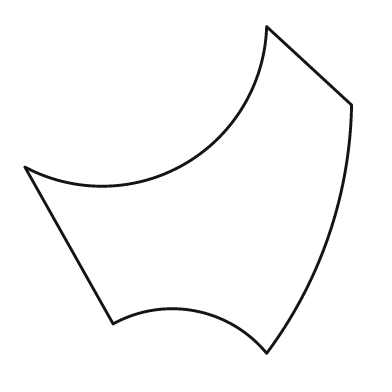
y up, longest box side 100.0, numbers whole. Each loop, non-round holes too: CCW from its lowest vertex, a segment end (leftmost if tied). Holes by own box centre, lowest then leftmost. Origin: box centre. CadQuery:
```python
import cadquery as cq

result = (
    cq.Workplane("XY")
    .moveTo(24.0, -50.0)
    .threePointArc((43.0, -14.0), (50.0, 26.0))
    .lineTo(24.0, 50.0)
    .threePointArc((-1.0, 8.0), (-50.0, 7.0))
    .lineTo(-23.0, -41.0)
    .threePointArc((2.0, -37.0), (24.0, -50.0))
    .close()
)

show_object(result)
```